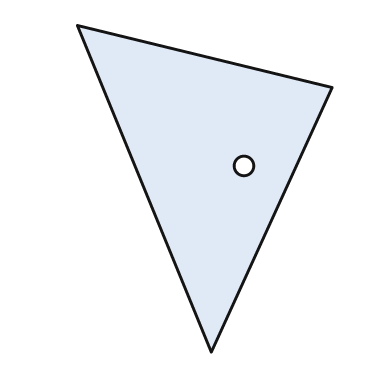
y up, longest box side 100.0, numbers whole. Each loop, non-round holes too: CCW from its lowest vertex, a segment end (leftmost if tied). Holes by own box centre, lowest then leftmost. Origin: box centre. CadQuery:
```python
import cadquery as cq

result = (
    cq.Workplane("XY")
    .moveTo(2.0, -50.0)
    .lineTo(39.0, 31.0)
    .lineTo(-39.0, 50.0)
    .close()
    .moveTo(12.0, 7.0)
    .circle(3.0)
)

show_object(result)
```